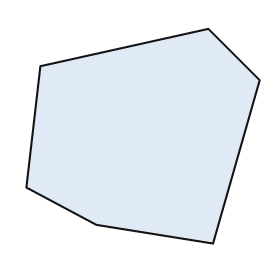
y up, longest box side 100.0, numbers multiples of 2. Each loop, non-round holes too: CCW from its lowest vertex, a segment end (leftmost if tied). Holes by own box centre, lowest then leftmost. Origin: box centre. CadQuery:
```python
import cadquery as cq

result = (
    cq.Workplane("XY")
    .moveTo(30.0, -46.0)
    .lineTo(50.0, 24.0)
    .lineTo(28.0, 46.0)
    .lineTo(-44.0, 30.0)
    .lineTo(-50.0, -22.0)
    .lineTo(-20.0, -38.0)
    .close()
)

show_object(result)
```